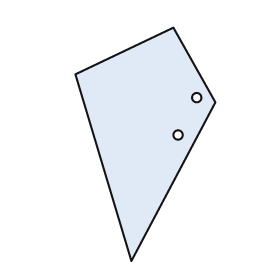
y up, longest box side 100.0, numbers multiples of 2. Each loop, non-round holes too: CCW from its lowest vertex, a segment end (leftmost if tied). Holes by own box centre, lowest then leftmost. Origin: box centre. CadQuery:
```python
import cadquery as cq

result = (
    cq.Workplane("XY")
    .moveTo(-6.0, -50.0)
    .lineTo(30.0, 18.0)
    .lineTo(12.0, 50.0)
    .lineTo(-30.0, 30.0)
    .close()
    .moveTo(14.0, 4.0)
    .circle(2.0)
    .moveTo(22.0, 20.0)
    .circle(2.0)
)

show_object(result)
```